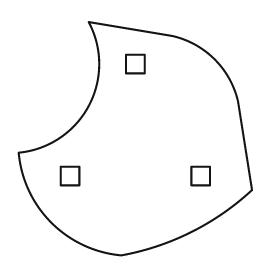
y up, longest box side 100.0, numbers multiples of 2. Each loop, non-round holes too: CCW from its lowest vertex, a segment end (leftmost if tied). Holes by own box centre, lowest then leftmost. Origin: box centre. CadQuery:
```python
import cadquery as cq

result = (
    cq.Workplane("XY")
    .moveTo(-6.0, -50.0)
    .threePointArc((24.0, -40.0), (50.0, -22.0))
    .lineTo(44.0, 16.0)
    .threePointArc((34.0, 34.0), (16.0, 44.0))
    .lineTo(-20.0, 50.0)
    .threePointArc((-20.0, 14.0), (-50.0, -6.0))
    .threePointArc((-36.0, -36.0), (-6.0, -50.0))
    .close()
    .moveTo(-32.0, -20.0)
    .lineTo(-24.0, -20.0)
    .lineTo(-24.0, -12.0)
    .lineTo(-32.0, -12.0)
    .close()
    .moveTo(24.0, -20.0)
    .lineTo(32.0, -20.0)
    .lineTo(32.0, -12.0)
    .lineTo(24.0, -12.0)
    .close()
    .moveTo(-4.0, 28.0)
    .lineTo(4.0, 28.0)
    .lineTo(4.0, 36.0)
    .lineTo(-4.0, 36.0)
    .close()
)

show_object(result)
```